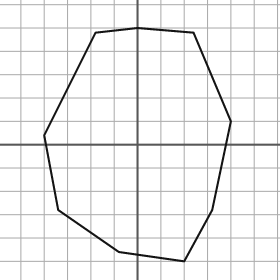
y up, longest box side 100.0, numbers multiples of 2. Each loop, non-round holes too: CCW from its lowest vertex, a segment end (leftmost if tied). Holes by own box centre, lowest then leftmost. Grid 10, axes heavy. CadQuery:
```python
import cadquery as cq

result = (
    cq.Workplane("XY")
    .moveTo(20.0, -50.0)
    .lineTo(32.0, -28.0)
    .lineTo(40.0, 10.0)
    .lineTo(24.0, 48.0)
    .lineTo(0.0, 50.0)
    .lineTo(-18.0, 48.0)
    .lineTo(-40.0, 4.0)
    .lineTo(-34.0, -28.0)
    .lineTo(-8.0, -46.0)
    .close()
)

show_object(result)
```